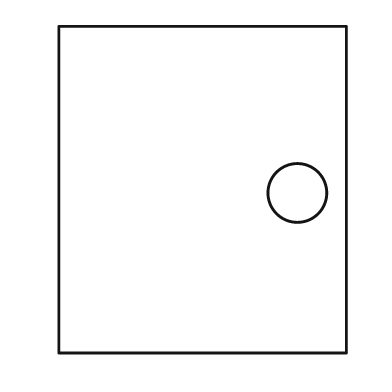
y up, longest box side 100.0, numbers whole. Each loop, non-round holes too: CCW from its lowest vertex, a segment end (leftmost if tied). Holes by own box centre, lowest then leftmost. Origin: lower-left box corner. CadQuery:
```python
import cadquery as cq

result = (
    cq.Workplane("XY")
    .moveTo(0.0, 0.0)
    .lineTo(88.0, 0.0)
    .lineTo(88.0, 100.0)
    .lineTo(0.0, 100.0)
    .close()
    .moveTo(73.0, 49.0)
    .circle(9.0)
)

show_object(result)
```